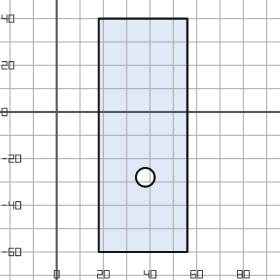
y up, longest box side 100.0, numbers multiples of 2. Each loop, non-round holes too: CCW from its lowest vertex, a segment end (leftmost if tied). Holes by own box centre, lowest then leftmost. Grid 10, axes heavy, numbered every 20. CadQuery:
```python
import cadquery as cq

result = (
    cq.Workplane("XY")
    .moveTo(18.0, -60.0)
    .lineTo(56.0, -60.0)
    .lineTo(56.0, 40.0)
    .lineTo(18.0, 40.0)
    .close()
    .moveTo(38.0, -28.0)
    .circle(4.0)
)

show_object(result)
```